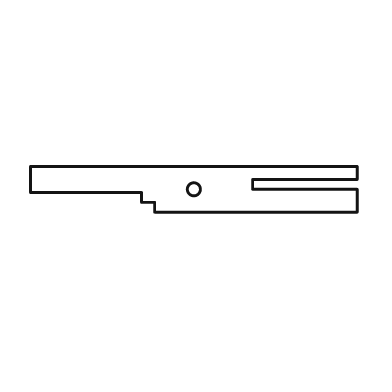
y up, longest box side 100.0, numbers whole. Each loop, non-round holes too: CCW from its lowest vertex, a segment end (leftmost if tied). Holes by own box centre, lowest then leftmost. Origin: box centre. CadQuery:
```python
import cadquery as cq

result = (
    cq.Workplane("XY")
    .moveTo(-12.0, -7.0)
    .lineTo(50.0, -7.0)
    .lineTo(50.0, 0.0)
    .lineTo(18.0, 0.0)
    .lineTo(18.0, 3.0)
    .lineTo(50.0, 3.0)
    .lineTo(50.0, 7.0)
    .lineTo(-50.0, 7.0)
    .lineTo(-50.0, -1.0)
    .lineTo(-16.0, -1.0)
    .lineTo(-16.0, -4.0)
    .lineTo(-12.0, -4.0)
    .close()
    .moveTo(0.0, 0.0)
    .circle(2.0)
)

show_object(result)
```